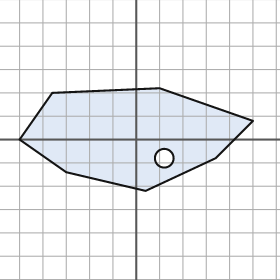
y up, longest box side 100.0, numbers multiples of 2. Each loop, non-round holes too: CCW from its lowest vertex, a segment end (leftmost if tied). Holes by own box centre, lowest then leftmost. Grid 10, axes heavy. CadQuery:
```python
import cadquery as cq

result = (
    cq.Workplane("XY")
    .moveTo(4.0, -22.0)
    .lineTo(34.0, -8.0)
    .lineTo(50.0, 8.0)
    .lineTo(10.0, 22.0)
    .lineTo(-36.0, 20.0)
    .lineTo(-50.0, 0.0)
    .lineTo(-30.0, -14.0)
    .close()
    .moveTo(12.0, -8.0)
    .circle(4.0)
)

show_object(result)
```